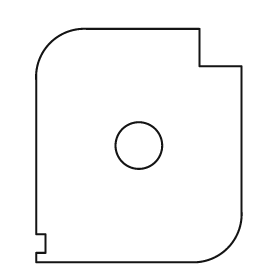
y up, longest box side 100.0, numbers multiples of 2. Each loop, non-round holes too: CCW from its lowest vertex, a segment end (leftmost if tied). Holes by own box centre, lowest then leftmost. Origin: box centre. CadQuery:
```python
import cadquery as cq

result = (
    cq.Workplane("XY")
    .moveTo(-44.0, -50.0)
    .lineTo(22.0, -50.0)
    .threePointArc((38.0, -44.0), (44.0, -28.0))
    .lineTo(44.0, 34.0)
    .lineTo(26.0, 34.0)
    .lineTo(26.0, 50.0)
    .lineTo(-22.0, 50.0)
    .threePointArc((-38.0, 44.0), (-44.0, 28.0))
    .lineTo(-44.0, -38.0)
    .lineTo(-40.0, -38.0)
    .lineTo(-40.0, -46.0)
    .lineTo(-44.0, -46.0)
    .close()
    .moveTo(0.0, 0.0)
    .circle(10.0)
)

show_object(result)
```